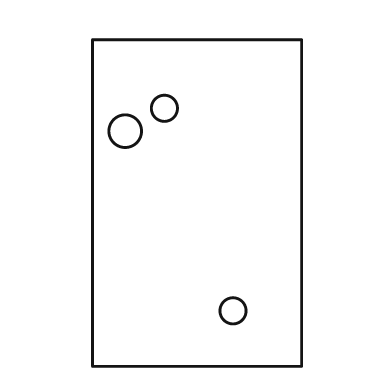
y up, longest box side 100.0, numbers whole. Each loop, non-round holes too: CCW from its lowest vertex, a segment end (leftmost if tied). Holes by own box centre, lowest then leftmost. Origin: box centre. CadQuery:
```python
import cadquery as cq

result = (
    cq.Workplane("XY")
    .moveTo(-32.0, -50.0)
    .lineTo(32.0, -50.0)
    .lineTo(32.0, 50.0)
    .lineTo(-32.0, 50.0)
    .close()
    .moveTo(11.0, -33.0)
    .circle(4.0)
    .moveTo(-22.0, 22.0)
    .circle(5.0)
    .moveTo(-10.0, 29.0)
    .circle(4.0)
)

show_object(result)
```